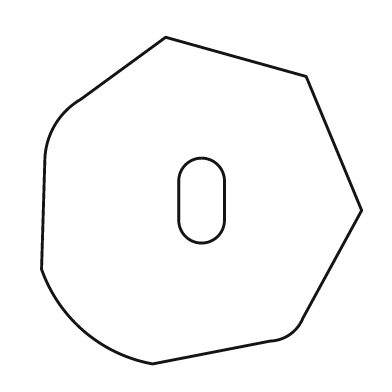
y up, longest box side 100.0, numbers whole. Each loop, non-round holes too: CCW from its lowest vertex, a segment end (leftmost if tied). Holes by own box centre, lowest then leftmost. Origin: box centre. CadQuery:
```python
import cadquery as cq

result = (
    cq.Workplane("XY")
    .moveTo(-15.0, -50.0)
    .lineTo(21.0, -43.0)
    .threePointArc((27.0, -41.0), (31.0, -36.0))
    .lineTo(49.0, -3.0)
    .lineTo(32.0, 38.0)
    .lineTo(-11.0, 50.0)
    .lineTo(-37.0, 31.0)
    .threePointArc((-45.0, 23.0), (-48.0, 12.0))
    .lineTo(-49.0, -21.0)
    .threePointArc((-36.0, -40.0), (-15.0, -50.0))
    .close()
    .moveTo(-7.0, -6.0)
    .threePointArc((0.0, -13.0), (7.0, -6.0))
    .lineTo(7.0, 6.0)
    .threePointArc((0.0, 13.0), (-7.0, 6.0))
    .close()
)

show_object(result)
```